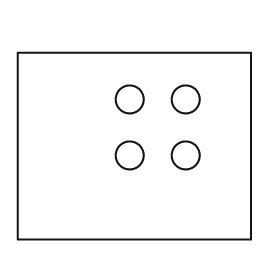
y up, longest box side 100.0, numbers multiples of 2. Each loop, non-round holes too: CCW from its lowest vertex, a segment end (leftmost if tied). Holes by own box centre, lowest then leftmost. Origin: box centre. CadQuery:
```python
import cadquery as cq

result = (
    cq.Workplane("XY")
    .moveTo(-50.0, -40.0)
    .lineTo(50.0, -40.0)
    .lineTo(50.0, 40.0)
    .lineTo(-50.0, 40.0)
    .close()
    .moveTo(-2.0, -4.0)
    .circle(6.0)
    .moveTo(22.0, -4.0)
    .circle(6.0)
    .moveTo(-2.0, 20.0)
    .circle(6.0)
    .moveTo(22.0, 20.0)
    .circle(6.0)
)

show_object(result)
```